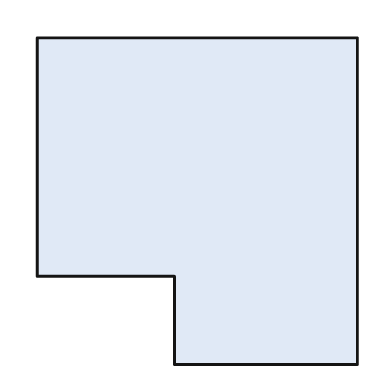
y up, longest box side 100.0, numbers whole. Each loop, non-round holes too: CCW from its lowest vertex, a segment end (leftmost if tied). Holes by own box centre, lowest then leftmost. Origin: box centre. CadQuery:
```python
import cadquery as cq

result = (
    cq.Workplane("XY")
    .moveTo(-7.0, -50.0)
    .lineTo(49.0, -50.0)
    .lineTo(49.0, 50.0)
    .lineTo(-49.0, 50.0)
    .lineTo(-49.0, -23.0)
    .lineTo(-7.0, -23.0)
    .close()
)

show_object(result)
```